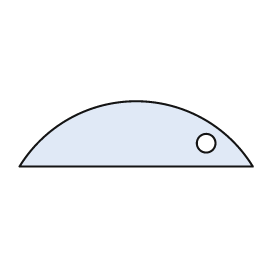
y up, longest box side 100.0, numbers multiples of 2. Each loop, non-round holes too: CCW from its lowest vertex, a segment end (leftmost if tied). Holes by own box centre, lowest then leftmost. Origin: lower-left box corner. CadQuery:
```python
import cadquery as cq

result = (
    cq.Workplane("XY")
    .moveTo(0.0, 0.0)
    .lineTo(100.0, 0.0)
    .threePointArc((50.0, 28.0), (0.0, 0.0))
    .close()
    .moveTo(80.0, 10.0)
    .circle(4.0)
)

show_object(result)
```